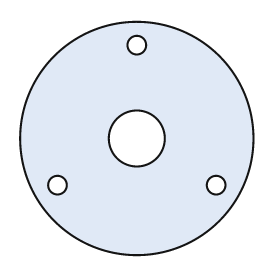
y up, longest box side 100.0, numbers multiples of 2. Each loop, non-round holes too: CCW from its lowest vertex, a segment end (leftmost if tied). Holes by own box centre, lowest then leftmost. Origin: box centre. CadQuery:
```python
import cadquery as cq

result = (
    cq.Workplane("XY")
    .moveTo(0.0, 0.0)
    .circle(50.0)
    .moveTo(-34.0, -20.0)
    .circle(4.0)
    .moveTo(34.0, -20.0)
    .circle(4.0)
    .moveTo(0.0, 0.0)
    .circle(12.0)
    .moveTo(0.0, 40.0)
    .circle(4.0)
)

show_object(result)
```